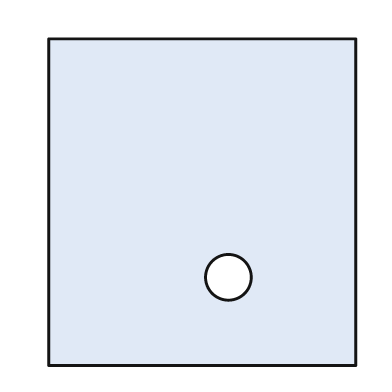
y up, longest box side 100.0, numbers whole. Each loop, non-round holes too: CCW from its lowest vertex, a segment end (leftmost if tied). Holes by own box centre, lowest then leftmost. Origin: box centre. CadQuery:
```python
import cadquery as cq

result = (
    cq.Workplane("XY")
    .moveTo(-47.0, -50.0)
    .lineTo(47.0, -50.0)
    .lineTo(47.0, 50.0)
    .lineTo(-47.0, 50.0)
    .close()
    .moveTo(8.0, -23.0)
    .circle(7.0)
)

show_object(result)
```